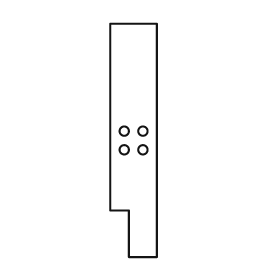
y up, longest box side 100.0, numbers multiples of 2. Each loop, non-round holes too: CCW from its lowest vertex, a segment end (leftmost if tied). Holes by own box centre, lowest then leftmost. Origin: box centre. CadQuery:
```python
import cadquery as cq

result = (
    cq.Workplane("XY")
    .moveTo(-2.0, -50.0)
    .lineTo(10.0, -50.0)
    .lineTo(10.0, 50.0)
    .lineTo(-10.0, 50.0)
    .lineTo(-10.0, -30.0)
    .lineTo(-2.0, -30.0)
    .close()
    .moveTo(-4.0, -4.0)
    .circle(2.0)
    .moveTo(4.0, -4.0)
    .circle(2.0)
    .moveTo(-4.0, 4.0)
    .circle(2.0)
    .moveTo(4.0, 4.0)
    .circle(2.0)
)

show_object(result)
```